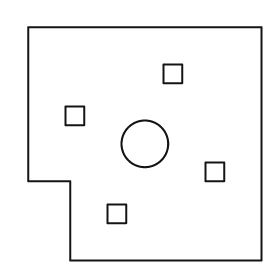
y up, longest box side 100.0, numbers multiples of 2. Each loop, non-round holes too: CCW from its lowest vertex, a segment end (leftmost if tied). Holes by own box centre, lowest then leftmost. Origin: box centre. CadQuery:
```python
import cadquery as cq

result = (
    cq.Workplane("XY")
    .moveTo(-32.0, -50.0)
    .lineTo(50.0, -50.0)
    .lineTo(50.0, 50.0)
    .lineTo(-50.0, 50.0)
    .lineTo(-50.0, -16.0)
    .lineTo(-32.0, -16.0)
    .close()
    .moveTo(-16.0, -34.0)
    .lineTo(-8.0, -34.0)
    .lineTo(-8.0, -26.0)
    .lineTo(-16.0, -26.0)
    .close()
    .moveTo(26.0, -16.0)
    .lineTo(34.0, -16.0)
    .lineTo(34.0, -8.0)
    .lineTo(26.0, -8.0)
    .close()
    .moveTo(0.0, 0.0)
    .circle(10.0)
    .moveTo(-34.0, 8.0)
    .lineTo(-26.0, 8.0)
    .lineTo(-26.0, 16.0)
    .lineTo(-34.0, 16.0)
    .close()
    .moveTo(8.0, 26.0)
    .lineTo(16.0, 26.0)
    .lineTo(16.0, 34.0)
    .lineTo(8.0, 34.0)
    .close()
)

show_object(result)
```